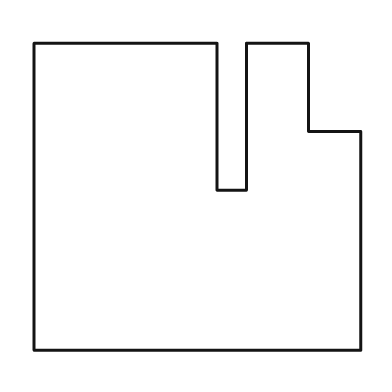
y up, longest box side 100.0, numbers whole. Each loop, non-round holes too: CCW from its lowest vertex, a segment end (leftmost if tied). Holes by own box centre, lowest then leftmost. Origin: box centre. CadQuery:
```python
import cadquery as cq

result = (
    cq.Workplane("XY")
    .moveTo(-50.0, -47.0)
    .lineTo(50.0, -47.0)
    .lineTo(50.0, 20.0)
    .lineTo(34.0, 20.0)
    .lineTo(34.0, 47.0)
    .lineTo(15.0, 47.0)
    .lineTo(15.0, 2.0)
    .lineTo(6.0, 2.0)
    .lineTo(6.0, 47.0)
    .lineTo(-50.0, 47.0)
    .close()
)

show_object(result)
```